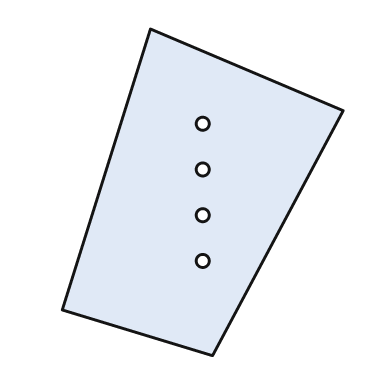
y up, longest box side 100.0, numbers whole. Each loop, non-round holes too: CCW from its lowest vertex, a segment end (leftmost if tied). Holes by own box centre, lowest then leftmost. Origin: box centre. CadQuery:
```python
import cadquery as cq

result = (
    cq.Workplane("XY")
    .moveTo(3.0, -50.0)
    .lineTo(43.0, 25.0)
    .lineTo(-16.0, 50.0)
    .lineTo(-43.0, -36.0)
    .close()
    .moveTo(0.0, -21.0)
    .circle(2.0)
    .moveTo(0.0, -7.0)
    .circle(2.0)
    .moveTo(0.0, 7.0)
    .circle(2.0)
    .moveTo(0.0, 21.0)
    .circle(2.0)
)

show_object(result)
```